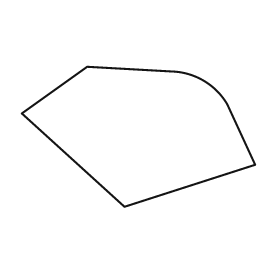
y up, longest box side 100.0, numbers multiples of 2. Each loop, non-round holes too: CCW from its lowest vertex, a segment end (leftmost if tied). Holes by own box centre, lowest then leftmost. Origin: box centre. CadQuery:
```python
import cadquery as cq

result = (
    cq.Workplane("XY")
    .moveTo(-6.0, -30.0)
    .lineTo(50.0, -12.0)
    .lineTo(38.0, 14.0)
    .threePointArc((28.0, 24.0), (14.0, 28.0))
    .lineTo(-22.0, 30.0)
    .lineTo(-50.0, 10.0)
    .close()
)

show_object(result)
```